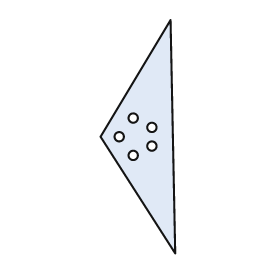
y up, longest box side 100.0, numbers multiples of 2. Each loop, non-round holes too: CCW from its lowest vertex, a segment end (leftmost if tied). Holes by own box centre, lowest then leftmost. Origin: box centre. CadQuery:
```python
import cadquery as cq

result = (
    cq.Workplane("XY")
    .moveTo(16.0, -50.0)
    .lineTo(14.0, 50.0)
    .lineTo(-16.0, 0.0)
    .close()
    .moveTo(-2.0, -8.0)
    .circle(2.0)
    .moveTo(6.0, -4.0)
    .circle(2.0)
    .moveTo(-8.0, 0.0)
    .circle(2.0)
    .moveTo(6.0, 4.0)
    .circle(2.0)
    .moveTo(-2.0, 8.0)
    .circle(2.0)
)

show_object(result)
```